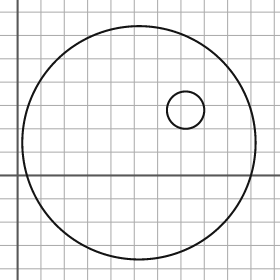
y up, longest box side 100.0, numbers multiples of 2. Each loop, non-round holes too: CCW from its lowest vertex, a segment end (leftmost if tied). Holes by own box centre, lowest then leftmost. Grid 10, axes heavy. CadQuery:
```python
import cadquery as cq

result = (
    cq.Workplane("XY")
    .moveTo(52.0, 14.0)
    .circle(50.0)
    .moveTo(72.0, 28.0)
    .circle(8.0)
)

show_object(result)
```